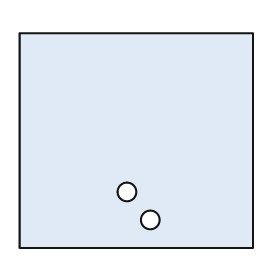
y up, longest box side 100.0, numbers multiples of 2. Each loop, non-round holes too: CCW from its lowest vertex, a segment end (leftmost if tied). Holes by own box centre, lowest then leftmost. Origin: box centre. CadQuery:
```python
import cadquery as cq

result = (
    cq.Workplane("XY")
    .moveTo(-50.0, -46.0)
    .lineTo(50.0, -46.0)
    .lineTo(50.0, 46.0)
    .lineTo(-50.0, 46.0)
    .close()
    .moveTo(6.0, -34.0)
    .circle(4.0)
    .moveTo(-4.0, -22.0)
    .circle(4.0)
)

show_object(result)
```